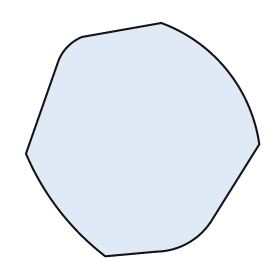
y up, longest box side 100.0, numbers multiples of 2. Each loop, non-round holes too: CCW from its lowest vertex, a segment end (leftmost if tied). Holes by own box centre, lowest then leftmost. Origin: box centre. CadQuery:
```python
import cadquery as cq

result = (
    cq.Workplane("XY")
    .moveTo(-16.0, -50.0)
    .lineTo(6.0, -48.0)
    .threePointArc((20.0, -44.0), (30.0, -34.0))
    .lineTo(50.0, -2.0)
    .threePointArc((36.0, 30.0), (8.0, 50.0))
    .lineTo(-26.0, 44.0)
    .threePointArc((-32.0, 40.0), (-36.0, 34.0))
    .lineTo(-50.0, -6.0)
    .threePointArc((-36.0, -30.0), (-16.0, -50.0))
    .close()
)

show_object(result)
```